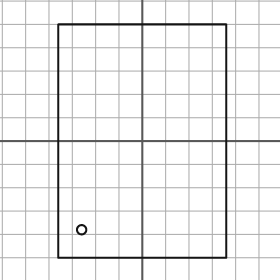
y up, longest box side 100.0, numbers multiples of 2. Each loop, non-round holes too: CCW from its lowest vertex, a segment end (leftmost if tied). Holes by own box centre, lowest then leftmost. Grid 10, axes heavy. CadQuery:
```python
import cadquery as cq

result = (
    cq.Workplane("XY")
    .moveTo(-36.0, -50.0)
    .lineTo(36.0, -50.0)
    .lineTo(36.0, 50.0)
    .lineTo(-36.0, 50.0)
    .close()
    .moveTo(-26.0, -38.0)
    .circle(2.0)
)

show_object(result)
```